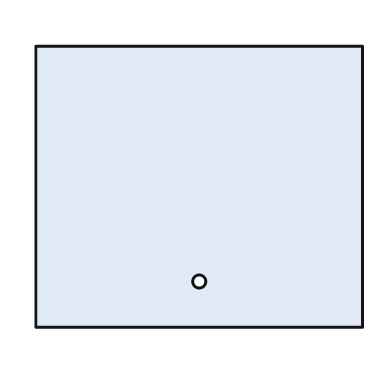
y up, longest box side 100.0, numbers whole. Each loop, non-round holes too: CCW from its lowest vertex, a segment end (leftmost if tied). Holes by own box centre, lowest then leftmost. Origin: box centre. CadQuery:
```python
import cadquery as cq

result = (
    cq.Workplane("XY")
    .moveTo(-50.0, -43.0)
    .lineTo(50.0, -43.0)
    .lineTo(50.0, 43.0)
    .lineTo(-50.0, 43.0)
    .close()
    .moveTo(0.0, -29.0)
    .circle(2.0)
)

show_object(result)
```